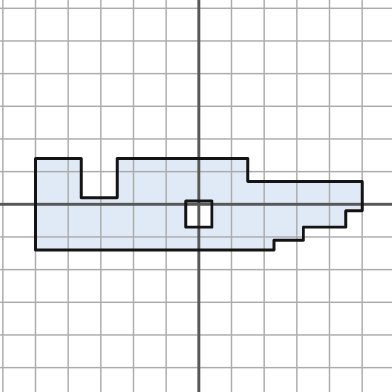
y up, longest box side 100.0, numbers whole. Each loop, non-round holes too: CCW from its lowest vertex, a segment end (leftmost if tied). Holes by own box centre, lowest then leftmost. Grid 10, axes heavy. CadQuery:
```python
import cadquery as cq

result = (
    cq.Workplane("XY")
    .moveTo(-50.0, -14.0)
    .lineTo(23.0, -14.0)
    .lineTo(23.0, -11.0)
    .lineTo(32.0, -11.0)
    .lineTo(32.0, -7.0)
    .lineTo(45.0, -7.0)
    .lineTo(45.0, -2.0)
    .lineTo(50.0, -2.0)
    .lineTo(50.0, 7.0)
    .lineTo(15.0, 7.0)
    .lineTo(15.0, 14.0)
    .lineTo(-25.0, 14.0)
    .lineTo(-25.0, 2.0)
    .lineTo(-36.0, 2.0)
    .lineTo(-36.0, 14.0)
    .lineTo(-50.0, 14.0)
    .close()
    .moveTo(-4.0, -7.0)
    .lineTo(4.0, -7.0)
    .lineTo(4.0, 1.0)
    .lineTo(-4.0, 1.0)
    .close()
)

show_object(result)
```